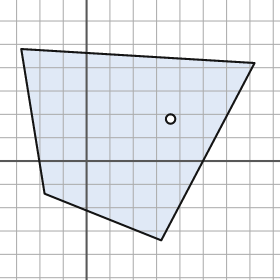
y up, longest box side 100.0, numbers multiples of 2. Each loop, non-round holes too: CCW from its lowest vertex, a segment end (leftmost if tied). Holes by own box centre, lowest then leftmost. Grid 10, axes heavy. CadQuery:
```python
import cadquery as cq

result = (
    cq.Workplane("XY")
    .moveTo(32.0, -34.0)
    .lineTo(72.0, 42.0)
    .lineTo(-28.0, 48.0)
    .lineTo(-18.0, -14.0)
    .close()
    .moveTo(36.0, 18.0)
    .circle(2.0)
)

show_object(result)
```